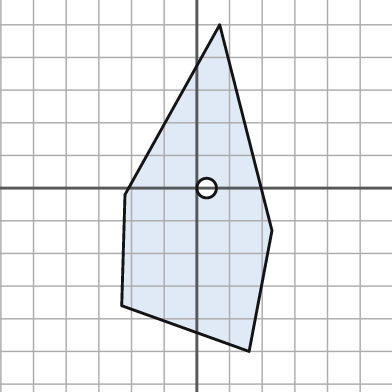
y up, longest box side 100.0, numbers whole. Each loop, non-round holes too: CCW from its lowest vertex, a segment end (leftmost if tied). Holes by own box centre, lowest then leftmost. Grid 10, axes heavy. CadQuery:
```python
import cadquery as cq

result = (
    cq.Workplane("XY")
    .moveTo(16.0, -50.0)
    .lineTo(23.0, -13.0)
    .lineTo(7.0, 50.0)
    .lineTo(-22.0, -2.0)
    .lineTo(-23.0, -36.0)
    .close()
    .moveTo(3.0, 0.0)
    .circle(3.0)
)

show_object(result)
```